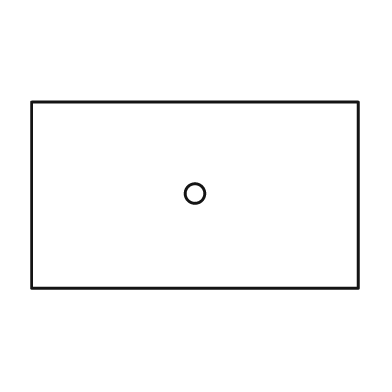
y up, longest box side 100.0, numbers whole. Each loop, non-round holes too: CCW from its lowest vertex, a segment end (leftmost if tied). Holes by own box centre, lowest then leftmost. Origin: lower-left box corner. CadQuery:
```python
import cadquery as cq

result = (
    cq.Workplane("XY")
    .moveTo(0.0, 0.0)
    .lineTo(100.0, 0.0)
    .lineTo(100.0, 57.0)
    .lineTo(0.0, 57.0)
    .close()
    .moveTo(50.0, 29.0)
    .circle(3.0)
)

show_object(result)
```